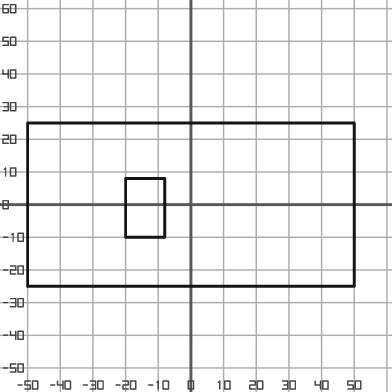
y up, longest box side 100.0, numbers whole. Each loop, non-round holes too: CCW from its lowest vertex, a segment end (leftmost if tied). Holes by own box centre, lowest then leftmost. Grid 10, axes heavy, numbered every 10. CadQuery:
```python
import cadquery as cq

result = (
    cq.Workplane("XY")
    .moveTo(-50.0, -25.0)
    .lineTo(50.0, -25.0)
    .lineTo(50.0, 25.0)
    .lineTo(-50.0, 25.0)
    .close()
    .moveTo(-20.0, -10.0)
    .lineTo(-8.0, -10.0)
    .lineTo(-8.0, 8.0)
    .lineTo(-20.0, 8.0)
    .close()
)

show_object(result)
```